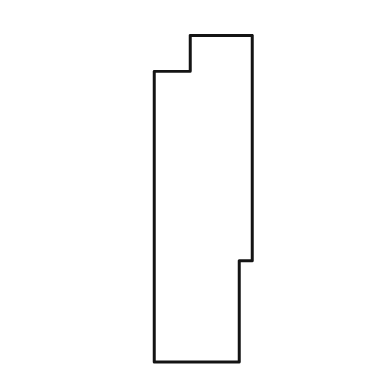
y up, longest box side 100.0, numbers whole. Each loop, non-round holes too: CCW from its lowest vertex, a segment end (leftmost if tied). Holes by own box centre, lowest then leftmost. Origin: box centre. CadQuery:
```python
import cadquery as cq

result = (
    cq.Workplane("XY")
    .moveTo(-15.0, -50.0)
    .lineTo(11.0, -50.0)
    .lineTo(11.0, -19.0)
    .lineTo(15.0, -19.0)
    .lineTo(15.0, 50.0)
    .lineTo(-4.0, 50.0)
    .lineTo(-4.0, 39.0)
    .lineTo(-15.0, 39.0)
    .close()
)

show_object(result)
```